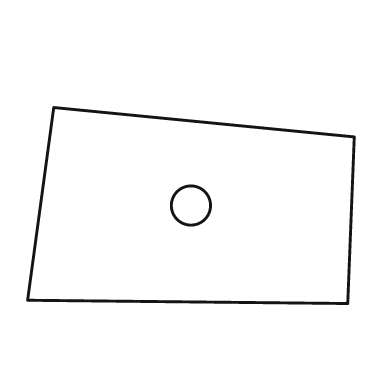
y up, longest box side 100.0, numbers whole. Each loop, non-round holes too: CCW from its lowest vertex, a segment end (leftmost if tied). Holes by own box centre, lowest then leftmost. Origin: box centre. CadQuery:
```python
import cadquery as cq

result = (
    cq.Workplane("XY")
    .moveTo(48.0, -30.0)
    .lineTo(50.0, 21.0)
    .lineTo(-42.0, 30.0)
    .lineTo(-50.0, -29.0)
    .close()
    .moveTo(0.0, 0.0)
    .circle(6.0)
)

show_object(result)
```